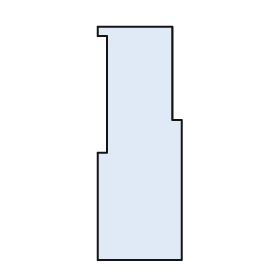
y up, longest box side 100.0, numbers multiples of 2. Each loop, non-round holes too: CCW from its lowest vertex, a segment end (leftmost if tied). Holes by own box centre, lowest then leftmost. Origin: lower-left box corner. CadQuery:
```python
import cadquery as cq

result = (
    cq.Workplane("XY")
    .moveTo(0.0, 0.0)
    .lineTo(36.0, 0.0)
    .lineTo(36.0, 60.0)
    .lineTo(32.0, 60.0)
    .lineTo(32.0, 100.0)
    .lineTo(0.0, 100.0)
    .lineTo(0.0, 96.0)
    .lineTo(4.0, 96.0)
    .lineTo(4.0, 46.0)
    .lineTo(0.0, 46.0)
    .close()
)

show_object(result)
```